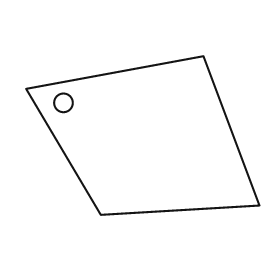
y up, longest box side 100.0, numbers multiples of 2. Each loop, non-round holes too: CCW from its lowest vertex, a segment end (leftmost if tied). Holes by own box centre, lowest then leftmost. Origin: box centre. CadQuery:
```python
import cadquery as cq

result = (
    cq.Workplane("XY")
    .moveTo(-18.0, -34.0)
    .lineTo(50.0, -30.0)
    .lineTo(26.0, 34.0)
    .lineTo(-50.0, 20.0)
    .close()
    .moveTo(-34.0, 14.0)
    .circle(4.0)
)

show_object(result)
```